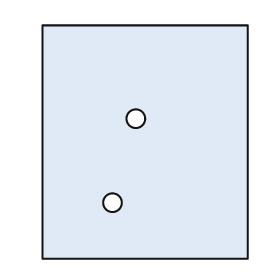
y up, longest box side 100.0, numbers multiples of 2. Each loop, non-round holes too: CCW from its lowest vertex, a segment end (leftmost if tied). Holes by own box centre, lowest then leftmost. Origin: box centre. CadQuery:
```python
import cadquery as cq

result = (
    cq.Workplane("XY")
    .moveTo(-44.0, -50.0)
    .lineTo(44.0, -50.0)
    .lineTo(44.0, 50.0)
    .lineTo(-44.0, 50.0)
    .close()
    .moveTo(-14.0, -26.0)
    .circle(4.0)
    .moveTo(-4.0, 10.0)
    .circle(4.0)
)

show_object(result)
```